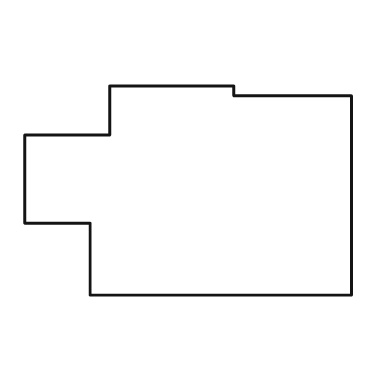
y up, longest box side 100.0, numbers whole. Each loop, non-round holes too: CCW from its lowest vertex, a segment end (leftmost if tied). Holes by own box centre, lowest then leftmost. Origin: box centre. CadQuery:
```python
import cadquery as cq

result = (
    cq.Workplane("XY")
    .moveTo(-30.0, -32.0)
    .lineTo(50.0, -32.0)
    .lineTo(50.0, 29.0)
    .lineTo(14.0, 29.0)
    .lineTo(14.0, 32.0)
    .lineTo(-24.0, 32.0)
    .lineTo(-24.0, 17.0)
    .lineTo(-50.0, 17.0)
    .lineTo(-50.0, -10.0)
    .lineTo(-30.0, -10.0)
    .close()
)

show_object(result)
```